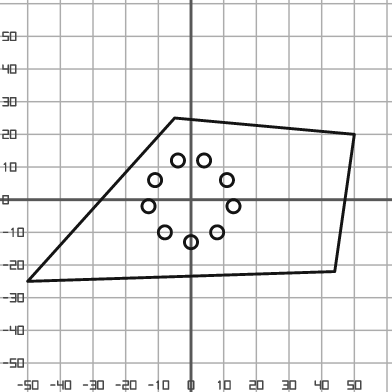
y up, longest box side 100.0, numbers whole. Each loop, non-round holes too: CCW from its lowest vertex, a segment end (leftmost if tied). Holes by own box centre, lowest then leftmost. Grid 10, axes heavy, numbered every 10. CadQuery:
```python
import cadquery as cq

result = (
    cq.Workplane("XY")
    .moveTo(-50.0, -25.0)
    .lineTo(44.0, -22.0)
    .lineTo(50.0, 20.0)
    .lineTo(-5.0, 25.0)
    .close()
    .moveTo(0.0, -13.0)
    .circle(2.0)
    .moveTo(-8.0, -10.0)
    .circle(2.0)
    .moveTo(8.0, -10.0)
    .circle(2.0)
    .moveTo(-13.0, -2.0)
    .circle(2.0)
    .moveTo(13.0, -2.0)
    .circle(2.0)
    .moveTo(-11.0, 6.0)
    .circle(2.0)
    .moveTo(11.0, 6.0)
    .circle(2.0)
    .moveTo(-4.0, 12.0)
    .circle(2.0)
    .moveTo(4.0, 12.0)
    .circle(2.0)
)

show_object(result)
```